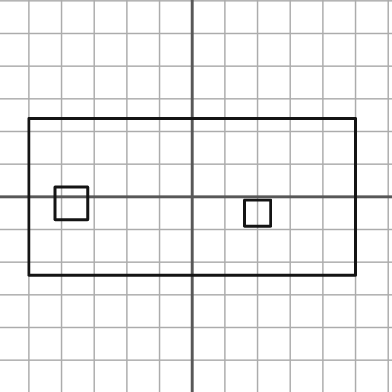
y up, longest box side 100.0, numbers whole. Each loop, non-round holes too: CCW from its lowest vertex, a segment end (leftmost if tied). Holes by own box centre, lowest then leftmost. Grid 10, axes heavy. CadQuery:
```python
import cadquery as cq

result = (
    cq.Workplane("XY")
    .moveTo(-50.0, -24.0)
    .lineTo(50.0, -24.0)
    .lineTo(50.0, 24.0)
    .lineTo(-50.0, 24.0)
    .close()
    .moveTo(16.0, -9.0)
    .lineTo(24.0, -9.0)
    .lineTo(24.0, -1.0)
    .lineTo(16.0, -1.0)
    .close()
    .moveTo(-42.0, -7.0)
    .lineTo(-32.0, -7.0)
    .lineTo(-32.0, 3.0)
    .lineTo(-42.0, 3.0)
    .close()
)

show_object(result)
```